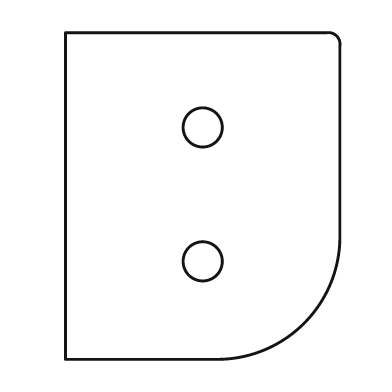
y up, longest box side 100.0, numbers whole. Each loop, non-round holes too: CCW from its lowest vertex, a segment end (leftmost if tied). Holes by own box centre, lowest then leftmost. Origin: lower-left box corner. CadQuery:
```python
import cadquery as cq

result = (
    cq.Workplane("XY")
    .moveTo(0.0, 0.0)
    .lineTo(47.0, 0.0)
    .threePointArc((73.0, 11.0), (84.0, 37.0))
    .lineTo(84.0, 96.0)
    .threePointArc((83.0, 99.0), (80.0, 100.0))
    .lineTo(0.0, 100.0)
    .close()
    .moveTo(42.0, 30.0)
    .circle(6.0)
    .moveTo(42.0, 71.0)
    .circle(6.0)
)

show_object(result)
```